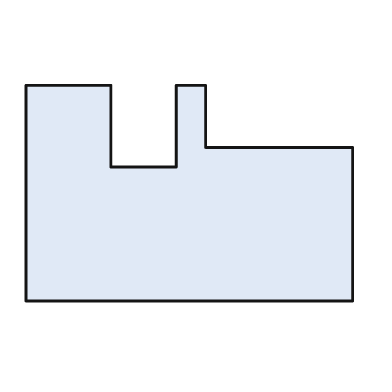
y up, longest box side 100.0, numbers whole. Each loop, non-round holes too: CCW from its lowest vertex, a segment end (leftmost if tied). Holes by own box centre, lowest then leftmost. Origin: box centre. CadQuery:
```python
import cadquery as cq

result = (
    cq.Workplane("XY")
    .moveTo(-50.0, -33.0)
    .lineTo(50.0, -33.0)
    .lineTo(50.0, 14.0)
    .lineTo(5.0, 14.0)
    .lineTo(5.0, 33.0)
    .lineTo(-4.0, 33.0)
    .lineTo(-4.0, 8.0)
    .lineTo(-24.0, 8.0)
    .lineTo(-24.0, 33.0)
    .lineTo(-50.0, 33.0)
    .close()
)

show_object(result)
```